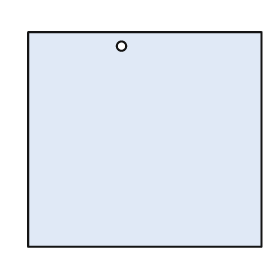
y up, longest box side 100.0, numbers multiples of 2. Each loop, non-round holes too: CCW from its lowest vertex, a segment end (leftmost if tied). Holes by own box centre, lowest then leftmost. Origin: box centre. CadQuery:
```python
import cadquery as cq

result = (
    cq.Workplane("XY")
    .moveTo(-50.0, -46.0)
    .lineTo(50.0, -46.0)
    .lineTo(50.0, 46.0)
    .lineTo(-50.0, 46.0)
    .close()
    .moveTo(-10.0, 40.0)
    .circle(2.0)
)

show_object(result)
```